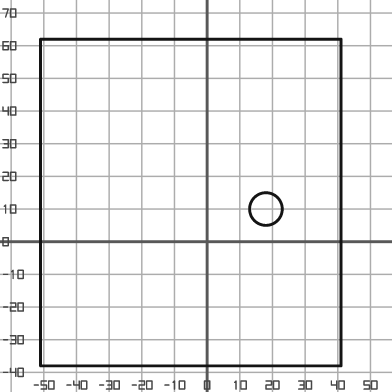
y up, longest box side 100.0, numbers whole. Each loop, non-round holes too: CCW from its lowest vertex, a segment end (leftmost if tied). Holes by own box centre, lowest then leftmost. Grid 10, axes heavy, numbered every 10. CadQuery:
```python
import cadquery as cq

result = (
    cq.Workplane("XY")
    .moveTo(-51.0, -38.0)
    .lineTo(41.0, -38.0)
    .lineTo(41.0, 62.0)
    .lineTo(-51.0, 62.0)
    .close()
    .moveTo(18.0, 10.0)
    .circle(5.0)
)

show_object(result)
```